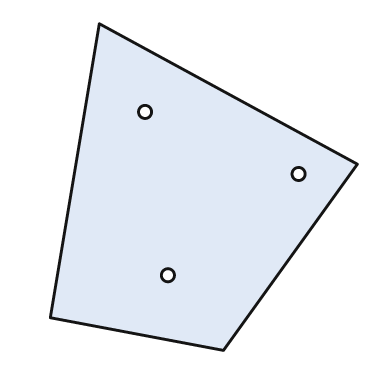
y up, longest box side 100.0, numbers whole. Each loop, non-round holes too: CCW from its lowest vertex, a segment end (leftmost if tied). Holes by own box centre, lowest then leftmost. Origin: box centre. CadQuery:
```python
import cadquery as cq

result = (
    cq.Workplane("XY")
    .moveTo(6.0, -50.0)
    .lineTo(47.0, 7.0)
    .lineTo(-32.0, 50.0)
    .lineTo(-47.0, -40.0)
    .close()
    .moveTo(-11.0, -27.0)
    .circle(2.0)
    .moveTo(29.0, 4.0)
    .circle(2.0)
    .moveTo(-18.0, 23.0)
    .circle(2.0)
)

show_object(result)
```